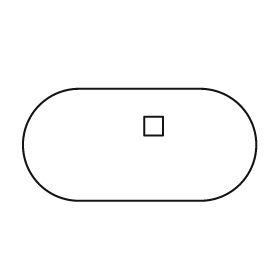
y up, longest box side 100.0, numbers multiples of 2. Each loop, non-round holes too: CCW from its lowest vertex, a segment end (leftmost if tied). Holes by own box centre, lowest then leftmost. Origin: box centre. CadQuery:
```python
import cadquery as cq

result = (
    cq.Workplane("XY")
    .moveTo(-26.0, -24.0)
    .lineTo(26.0, -24.0)
    .threePointArc((50.0, 0.0), (26.0, 24.0))
    .lineTo(-26.0, 24.0)
    .threePointArc((-50.0, 0.0), (-26.0, -24.0))
    .close()
    .moveTo(2.0, 4.0)
    .lineTo(10.0, 4.0)
    .lineTo(10.0, 12.0)
    .lineTo(2.0, 12.0)
    .close()
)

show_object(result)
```